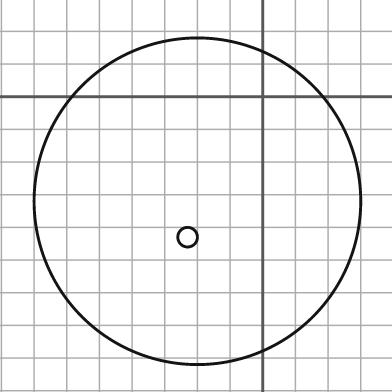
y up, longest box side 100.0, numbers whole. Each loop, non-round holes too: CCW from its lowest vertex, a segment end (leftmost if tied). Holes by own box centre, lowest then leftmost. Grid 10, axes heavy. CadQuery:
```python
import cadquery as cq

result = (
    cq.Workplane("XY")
    .moveTo(-20.0, -32.0)
    .circle(50.0)
    .moveTo(-23.0, -43.0)
    .circle(3.0)
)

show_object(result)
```